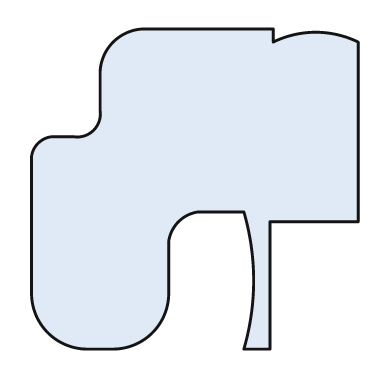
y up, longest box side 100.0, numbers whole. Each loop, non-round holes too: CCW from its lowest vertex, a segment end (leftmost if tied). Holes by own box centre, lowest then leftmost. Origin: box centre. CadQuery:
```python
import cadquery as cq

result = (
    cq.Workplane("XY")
    .moveTo(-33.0, -49.0)
    .lineTo(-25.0, -49.0)
    .threePointArc((-13.0, -44.0), (-8.0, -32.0))
    .lineTo(-8.0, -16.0)
    .threePointArc((-5.0, -10.0), (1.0, -7.0))
    .lineTo(15.0, -7.0)
    .threePointArc((18.0, -28.0), (15.0, -49.0))
    .lineTo(23.0, -49.0)
    .lineTo(23.0, -10.0)
    .lineTo(50.0, -10.0)
    .lineTo(50.0, 45.0)
    .threePointArc((37.0, 48.0), (24.0, 45.0))
    .lineTo(24.0, 49.0)
    .lineTo(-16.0, 49.0)
    .threePointArc((-25.0, 45.0), (-29.0, 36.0))
    .lineTo(-29.0, 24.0)
    .threePointArc((-31.0, 18.0), (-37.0, 16.0))
    .lineTo(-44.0, 16.0)
    .threePointArc((-48.0, 14.0), (-50.0, 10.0))
    .lineTo(-50.0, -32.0)
    .threePointArc((-45.0, -44.0), (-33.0, -49.0))
    .close()
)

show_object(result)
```